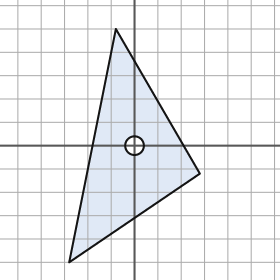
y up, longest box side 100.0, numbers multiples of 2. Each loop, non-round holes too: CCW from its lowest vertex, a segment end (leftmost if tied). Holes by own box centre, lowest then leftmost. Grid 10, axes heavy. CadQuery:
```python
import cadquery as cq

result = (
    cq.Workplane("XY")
    .moveTo(-28.0, -50.0)
    .lineTo(28.0, -12.0)
    .lineTo(-8.0, 50.0)
    .close()
    .moveTo(0.0, 0.0)
    .circle(4.0)
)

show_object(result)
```